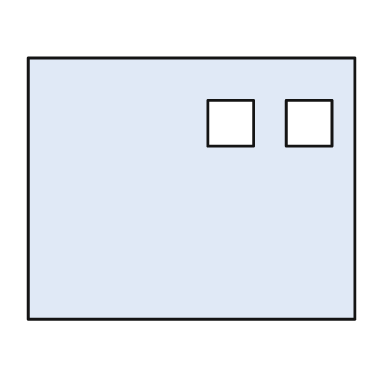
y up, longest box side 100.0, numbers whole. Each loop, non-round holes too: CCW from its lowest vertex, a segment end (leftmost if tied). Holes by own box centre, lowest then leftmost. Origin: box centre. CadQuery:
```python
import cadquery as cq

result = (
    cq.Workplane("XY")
    .moveTo(-50.0, -40.0)
    .lineTo(50.0, -40.0)
    .lineTo(50.0, 40.0)
    .lineTo(-50.0, 40.0)
    .close()
    .moveTo(5.0, 13.0)
    .lineTo(19.0, 13.0)
    .lineTo(19.0, 27.0)
    .lineTo(5.0, 27.0)
    .close()
    .moveTo(29.0, 13.0)
    .lineTo(43.0, 13.0)
    .lineTo(43.0, 27.0)
    .lineTo(29.0, 27.0)
    .close()
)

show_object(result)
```